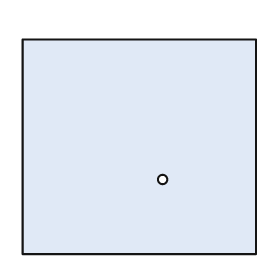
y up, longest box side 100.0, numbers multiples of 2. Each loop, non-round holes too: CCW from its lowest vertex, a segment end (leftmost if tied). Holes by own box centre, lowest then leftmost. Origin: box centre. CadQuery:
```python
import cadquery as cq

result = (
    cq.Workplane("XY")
    .moveTo(-50.0, -46.0)
    .lineTo(50.0, -46.0)
    .lineTo(50.0, 46.0)
    .lineTo(-50.0, 46.0)
    .close()
    .moveTo(10.0, -14.0)
    .circle(2.0)
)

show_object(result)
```